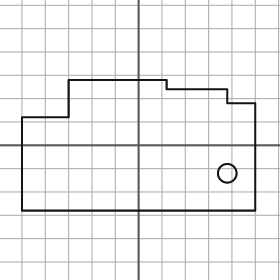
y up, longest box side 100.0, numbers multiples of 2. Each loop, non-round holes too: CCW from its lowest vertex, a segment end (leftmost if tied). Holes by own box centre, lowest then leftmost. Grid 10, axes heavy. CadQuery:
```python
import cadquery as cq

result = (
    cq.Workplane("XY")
    .moveTo(-50.0, -28.0)
    .lineTo(50.0, -28.0)
    .lineTo(50.0, 18.0)
    .lineTo(38.0, 18.0)
    .lineTo(38.0, 24.0)
    .lineTo(12.0, 24.0)
    .lineTo(12.0, 28.0)
    .lineTo(-30.0, 28.0)
    .lineTo(-30.0, 12.0)
    .lineTo(-50.0, 12.0)
    .close()
    .moveTo(38.0, -12.0)
    .circle(4.0)
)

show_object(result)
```